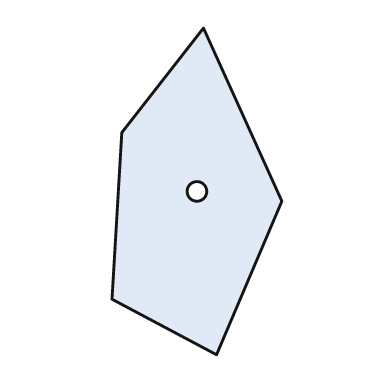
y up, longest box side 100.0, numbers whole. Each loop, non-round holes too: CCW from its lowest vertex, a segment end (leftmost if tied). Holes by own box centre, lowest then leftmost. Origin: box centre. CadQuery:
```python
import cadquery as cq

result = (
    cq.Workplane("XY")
    .moveTo(6.0, -50.0)
    .lineTo(26.0, -3.0)
    .lineTo(2.0, 50.0)
    .lineTo(-23.0, 18.0)
    .lineTo(-26.0, -33.0)
    .close()
    .moveTo(0.0, 0.0)
    .circle(3.0)
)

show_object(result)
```